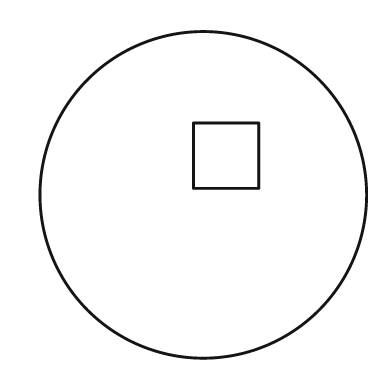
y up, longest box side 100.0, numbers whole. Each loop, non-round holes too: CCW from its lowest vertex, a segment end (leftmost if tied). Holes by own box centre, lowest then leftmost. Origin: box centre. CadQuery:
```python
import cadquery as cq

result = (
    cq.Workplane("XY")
    .moveTo(0.0, 0.0)
    .circle(50.0)
    .moveTo(-3.0, 2.0)
    .lineTo(17.0, 2.0)
    .lineTo(17.0, 22.0)
    .lineTo(-3.0, 22.0)
    .close()
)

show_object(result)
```